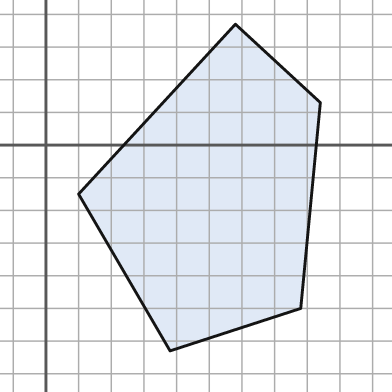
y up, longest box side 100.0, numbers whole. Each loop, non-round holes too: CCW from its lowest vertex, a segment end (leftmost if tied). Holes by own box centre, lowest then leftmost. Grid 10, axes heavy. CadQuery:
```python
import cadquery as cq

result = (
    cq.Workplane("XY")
    .moveTo(38.0, -63.0)
    .lineTo(78.0, -50.0)
    .lineTo(84.0, 13.0)
    .lineTo(58.0, 37.0)
    .lineTo(10.0, -15.0)
    .close()
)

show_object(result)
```